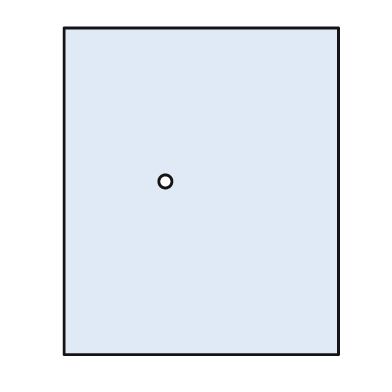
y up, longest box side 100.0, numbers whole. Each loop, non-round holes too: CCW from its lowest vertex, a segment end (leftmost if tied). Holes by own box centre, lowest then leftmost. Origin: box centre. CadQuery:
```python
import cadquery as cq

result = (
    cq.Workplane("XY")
    .moveTo(-42.0, -50.0)
    .lineTo(42.0, -50.0)
    .lineTo(42.0, 50.0)
    .lineTo(-42.0, 50.0)
    .close()
    .moveTo(-11.0, 3.0)
    .circle(2.0)
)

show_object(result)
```